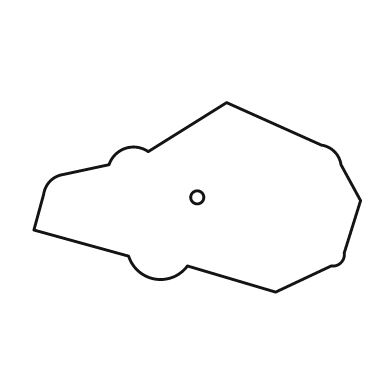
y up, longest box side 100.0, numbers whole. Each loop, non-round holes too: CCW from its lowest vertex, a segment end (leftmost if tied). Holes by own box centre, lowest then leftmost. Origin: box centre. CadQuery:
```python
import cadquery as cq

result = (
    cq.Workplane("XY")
    .moveTo(24.0, -29.0)
    .lineTo(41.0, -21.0)
    .threePointArc((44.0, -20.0), (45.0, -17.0))
    .lineTo(50.0, -1.0)
    .lineTo(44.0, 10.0)
    .threePointArc((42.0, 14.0), (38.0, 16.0))
    .lineTo(9.0, 29.0)
    .lineTo(-15.0, 14.0)
    .threePointArc((-22.0, 15.0), (-27.0, 10.0))
    .lineTo(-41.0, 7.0)
    .threePointArc((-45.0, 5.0), (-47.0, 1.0))
    .lineTo(-50.0, -10.0)
    .lineTo(-21.0, -18.0)
    .threePointArc((-13.0, -25.0), (-3.0, -21.0))
    .close()
    .moveTo(0.0, 0.0)
    .circle(2.0)
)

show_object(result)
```